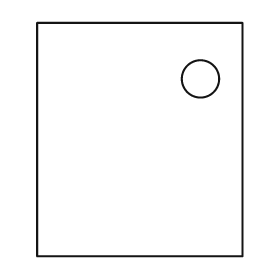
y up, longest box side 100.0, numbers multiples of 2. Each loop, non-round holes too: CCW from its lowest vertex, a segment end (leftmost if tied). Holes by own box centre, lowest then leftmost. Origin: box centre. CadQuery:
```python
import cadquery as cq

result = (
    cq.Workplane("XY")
    .moveTo(-44.0, -50.0)
    .lineTo(44.0, -50.0)
    .lineTo(44.0, 50.0)
    .lineTo(-44.0, 50.0)
    .close()
    .moveTo(26.0, 26.0)
    .circle(8.0)
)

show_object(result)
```